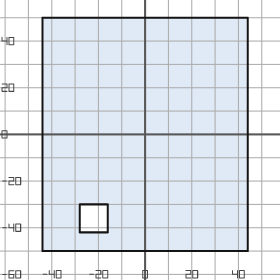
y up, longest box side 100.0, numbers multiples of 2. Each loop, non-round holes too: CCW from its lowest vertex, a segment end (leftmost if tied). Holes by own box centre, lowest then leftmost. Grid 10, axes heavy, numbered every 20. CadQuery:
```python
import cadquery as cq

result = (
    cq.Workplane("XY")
    .moveTo(-44.0, -50.0)
    .lineTo(44.0, -50.0)
    .lineTo(44.0, 50.0)
    .lineTo(-44.0, 50.0)
    .close()
    .moveTo(-28.0, -42.0)
    .lineTo(-16.0, -42.0)
    .lineTo(-16.0, -30.0)
    .lineTo(-28.0, -30.0)
    .close()
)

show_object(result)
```